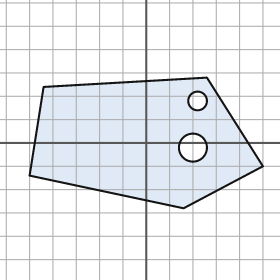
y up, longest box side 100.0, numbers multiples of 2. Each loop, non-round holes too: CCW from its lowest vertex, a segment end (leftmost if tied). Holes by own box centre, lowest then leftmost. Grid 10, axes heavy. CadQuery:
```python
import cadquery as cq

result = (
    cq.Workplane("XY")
    .moveTo(16.0, -28.0)
    .lineTo(50.0, -10.0)
    .lineTo(26.0, 28.0)
    .lineTo(-44.0, 24.0)
    .lineTo(-50.0, -14.0)
    .close()
    .moveTo(20.0, -2.0)
    .circle(6.0)
    .moveTo(22.0, 18.0)
    .circle(4.0)
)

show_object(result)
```